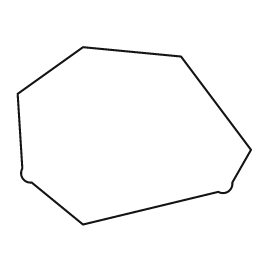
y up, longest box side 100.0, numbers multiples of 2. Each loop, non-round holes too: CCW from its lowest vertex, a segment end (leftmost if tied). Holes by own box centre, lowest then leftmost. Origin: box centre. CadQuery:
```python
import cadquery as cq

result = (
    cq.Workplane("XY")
    .moveTo(-22.0, -38.0)
    .lineTo(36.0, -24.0)
    .threePointArc((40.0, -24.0), (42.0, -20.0))
    .lineTo(50.0, -6.0)
    .lineTo(20.0, 34.0)
    .lineTo(-22.0, 38.0)
    .lineTo(-50.0, 18.0)
    .lineTo(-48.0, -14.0)
    .threePointArc((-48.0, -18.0), (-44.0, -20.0))
    .close()
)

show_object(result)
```